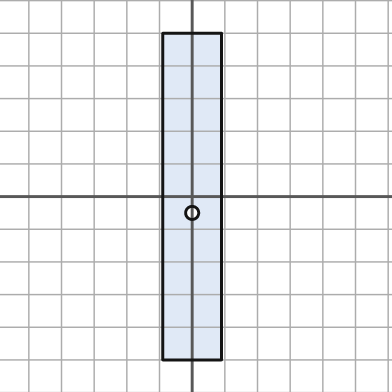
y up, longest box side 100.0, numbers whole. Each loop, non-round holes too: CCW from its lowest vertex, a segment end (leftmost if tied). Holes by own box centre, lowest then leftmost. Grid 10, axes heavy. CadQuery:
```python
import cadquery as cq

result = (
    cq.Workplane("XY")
    .moveTo(-9.0, -50.0)
    .lineTo(9.0, -50.0)
    .lineTo(9.0, 50.0)
    .lineTo(-9.0, 50.0)
    .close()
    .moveTo(0.0, -5.0)
    .circle(2.0)
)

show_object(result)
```